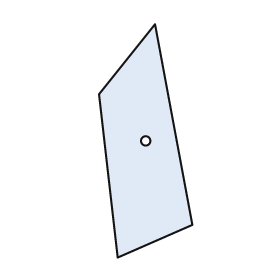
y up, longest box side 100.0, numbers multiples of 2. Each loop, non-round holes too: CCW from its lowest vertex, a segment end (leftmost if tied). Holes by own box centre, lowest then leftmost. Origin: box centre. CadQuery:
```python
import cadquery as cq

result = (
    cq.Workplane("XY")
    .moveTo(-12.0, -50.0)
    .lineTo(20.0, -36.0)
    .lineTo(4.0, 50.0)
    .lineTo(-20.0, 20.0)
    .close()
    .moveTo(0.0, 0.0)
    .circle(2.0)
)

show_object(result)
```